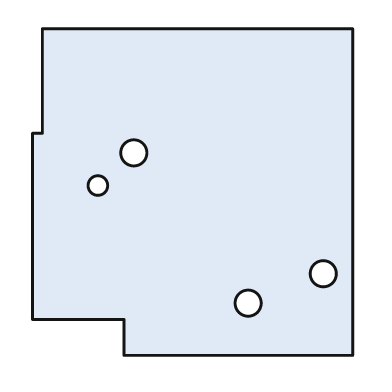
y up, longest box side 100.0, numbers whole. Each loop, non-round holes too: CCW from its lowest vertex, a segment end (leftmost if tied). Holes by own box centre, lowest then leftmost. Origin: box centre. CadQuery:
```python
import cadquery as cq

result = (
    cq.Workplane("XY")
    .moveTo(-21.0, -50.0)
    .lineTo(49.0, -50.0)
    .lineTo(49.0, 50.0)
    .lineTo(-46.0, 50.0)
    .lineTo(-46.0, 18.0)
    .lineTo(-49.0, 18.0)
    .lineTo(-49.0, -39.0)
    .lineTo(-21.0, -39.0)
    .close()
    .moveTo(17.0, -34.0)
    .circle(4.0)
    .moveTo(40.0, -25.0)
    .circle(4.0)
    .moveTo(-29.0, 2.0)
    .circle(3.0)
    .moveTo(-18.0, 12.0)
    .circle(4.0)
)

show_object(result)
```